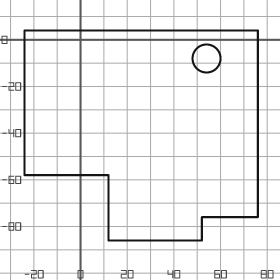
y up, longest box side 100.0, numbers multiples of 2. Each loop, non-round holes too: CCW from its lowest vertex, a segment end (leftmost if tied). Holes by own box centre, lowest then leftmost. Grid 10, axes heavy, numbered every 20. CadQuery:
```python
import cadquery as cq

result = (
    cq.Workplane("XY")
    .moveTo(12.0, -86.0)
    .lineTo(52.0, -86.0)
    .lineTo(52.0, -76.0)
    .lineTo(76.0, -76.0)
    .lineTo(76.0, 4.0)
    .lineTo(-24.0, 4.0)
    .lineTo(-24.0, -58.0)
    .lineTo(12.0, -58.0)
    .close()
    .moveTo(54.0, -8.0)
    .circle(6.0)
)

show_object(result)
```